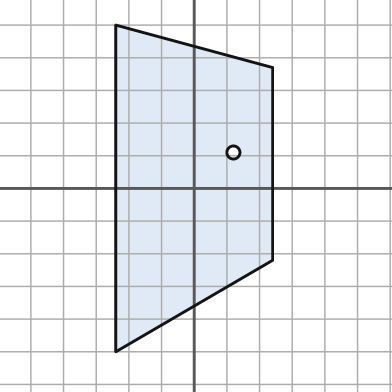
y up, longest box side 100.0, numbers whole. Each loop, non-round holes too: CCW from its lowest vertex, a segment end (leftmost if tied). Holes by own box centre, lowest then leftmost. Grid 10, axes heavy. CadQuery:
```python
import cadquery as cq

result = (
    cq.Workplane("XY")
    .moveTo(-24.0, -50.0)
    .lineTo(24.0, -22.0)
    .lineTo(24.0, 37.0)
    .lineTo(-24.0, 50.0)
    .close()
    .moveTo(12.0, 11.0)
    .circle(2.0)
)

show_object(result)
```